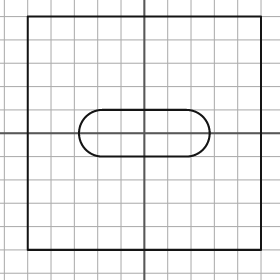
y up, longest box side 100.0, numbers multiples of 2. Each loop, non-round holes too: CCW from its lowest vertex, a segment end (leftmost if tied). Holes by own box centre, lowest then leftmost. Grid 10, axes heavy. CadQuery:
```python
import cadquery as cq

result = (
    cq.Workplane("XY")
    .moveTo(-50.0, -50.0)
    .lineTo(50.0, -50.0)
    .lineTo(50.0, 50.0)
    .lineTo(-50.0, 50.0)
    .close()
    .moveTo(-18.0, -10.0)
    .lineTo(18.0, -10.0)
    .threePointArc((28.0, 0.0), (18.0, 10.0))
    .lineTo(-18.0, 10.0)
    .threePointArc((-28.0, 0.0), (-18.0, -10.0))
    .close()
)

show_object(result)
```